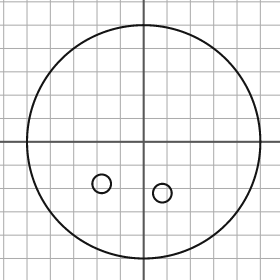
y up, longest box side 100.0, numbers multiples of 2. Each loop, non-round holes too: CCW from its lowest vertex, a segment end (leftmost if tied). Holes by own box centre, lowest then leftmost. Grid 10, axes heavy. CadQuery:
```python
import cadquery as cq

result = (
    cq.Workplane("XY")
    .moveTo(0.0, 0.0)
    .circle(50.0)
    .moveTo(8.0, -22.0)
    .circle(4.0)
    .moveTo(-18.0, -18.0)
    .circle(4.0)
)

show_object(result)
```